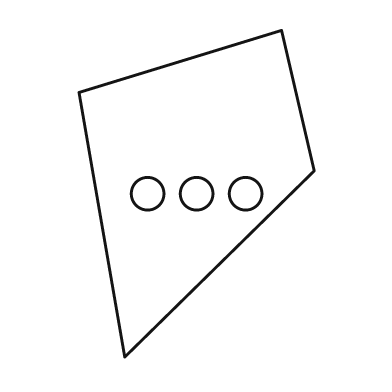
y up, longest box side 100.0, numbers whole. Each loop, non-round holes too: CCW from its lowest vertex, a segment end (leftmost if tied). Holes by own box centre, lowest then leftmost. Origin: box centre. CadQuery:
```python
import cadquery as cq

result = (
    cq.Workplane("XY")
    .moveTo(-22.0, -50.0)
    .lineTo(36.0, 7.0)
    .lineTo(26.0, 50.0)
    .lineTo(-36.0, 31.0)
    .close()
    .moveTo(-15.0, 0.0)
    .circle(5.0)
    .moveTo(0.0, 0.0)
    .circle(5.0)
    .moveTo(15.0, 0.0)
    .circle(5.0)
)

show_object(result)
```